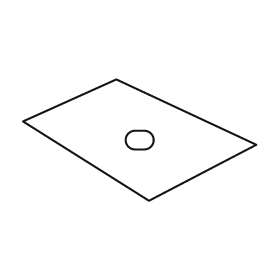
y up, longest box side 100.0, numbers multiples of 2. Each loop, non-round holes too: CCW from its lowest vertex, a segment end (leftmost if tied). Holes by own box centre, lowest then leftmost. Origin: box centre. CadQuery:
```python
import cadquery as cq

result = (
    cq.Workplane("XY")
    .moveTo(4.0, -26.0)
    .lineTo(50.0, -2.0)
    .lineTo(-10.0, 26.0)
    .lineTo(-50.0, 8.0)
    .close()
    .moveTo(-2.0, -4.0)
    .lineTo(2.0, -4.0)
    .threePointArc((6.0, 0.0), (2.0, 4.0))
    .lineTo(-2.0, 4.0)
    .threePointArc((-6.0, 0.0), (-2.0, -4.0))
    .close()
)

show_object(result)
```